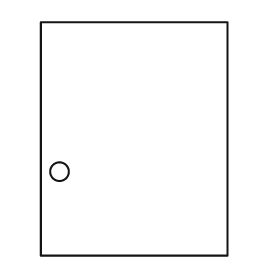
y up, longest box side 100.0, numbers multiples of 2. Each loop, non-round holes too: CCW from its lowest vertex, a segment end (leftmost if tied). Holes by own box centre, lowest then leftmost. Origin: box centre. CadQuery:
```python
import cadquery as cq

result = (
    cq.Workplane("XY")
    .moveTo(-40.0, -50.0)
    .lineTo(40.0, -50.0)
    .lineTo(40.0, 50.0)
    .lineTo(-40.0, 50.0)
    .close()
    .moveTo(-32.0, -14.0)
    .circle(4.0)
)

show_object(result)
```